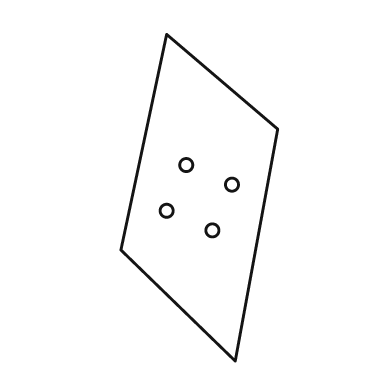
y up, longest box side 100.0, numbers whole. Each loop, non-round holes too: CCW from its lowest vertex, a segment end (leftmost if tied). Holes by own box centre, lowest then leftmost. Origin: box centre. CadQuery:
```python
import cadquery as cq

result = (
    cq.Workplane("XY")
    .moveTo(11.0, -50.0)
    .lineTo(24.0, 21.0)
    .lineTo(-10.0, 50.0)
    .lineTo(-24.0, -16.0)
    .close()
    .moveTo(4.0, -10.0)
    .circle(2.0)
    .moveTo(-10.0, -4.0)
    .circle(2.0)
    .moveTo(10.0, 4.0)
    .circle(2.0)
    .moveTo(-4.0, 10.0)
    .circle(2.0)
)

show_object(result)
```